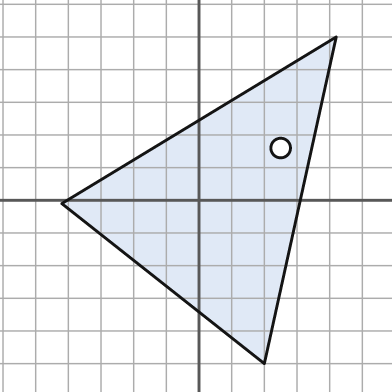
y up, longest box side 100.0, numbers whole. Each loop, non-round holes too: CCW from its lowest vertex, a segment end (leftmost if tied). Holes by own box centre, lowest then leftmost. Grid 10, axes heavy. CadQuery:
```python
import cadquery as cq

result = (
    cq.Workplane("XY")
    .moveTo(20.0, -50.0)
    .lineTo(42.0, 50.0)
    .lineTo(-42.0, -1.0)
    .close()
    .moveTo(25.0, 16.0)
    .circle(3.0)
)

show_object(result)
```